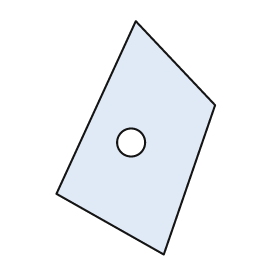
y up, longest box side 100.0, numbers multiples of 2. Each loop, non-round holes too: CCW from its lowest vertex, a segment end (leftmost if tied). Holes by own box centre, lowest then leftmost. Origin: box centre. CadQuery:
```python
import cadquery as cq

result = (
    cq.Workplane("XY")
    .moveTo(12.0, -50.0)
    .lineTo(34.0, 14.0)
    .lineTo(0.0, 50.0)
    .lineTo(-34.0, -24.0)
    .close()
    .moveTo(-2.0, -2.0)
    .circle(6.0)
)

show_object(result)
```